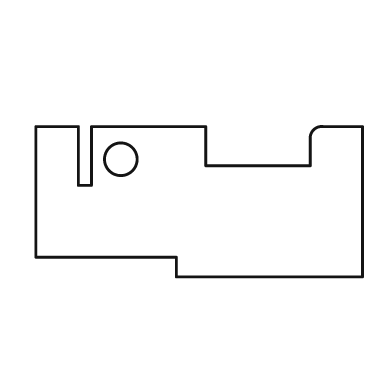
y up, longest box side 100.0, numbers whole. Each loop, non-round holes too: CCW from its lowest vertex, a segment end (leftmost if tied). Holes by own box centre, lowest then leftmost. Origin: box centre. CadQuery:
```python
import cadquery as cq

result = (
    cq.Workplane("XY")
    .moveTo(-7.0, -23.0)
    .lineTo(50.0, -23.0)
    .lineTo(50.0, 23.0)
    .lineTo(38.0, 23.0)
    .threePointArc((35.0, 22.0), (34.0, 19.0))
    .lineTo(34.0, 11.0)
    .lineTo(2.0, 11.0)
    .lineTo(2.0, 23.0)
    .lineTo(-33.0, 23.0)
    .lineTo(-33.0, 5.0)
    .lineTo(-37.0, 5.0)
    .lineTo(-37.0, 23.0)
    .lineTo(-50.0, 23.0)
    .lineTo(-50.0, -17.0)
    .lineTo(-7.0, -17.0)
    .close()
    .moveTo(-24.0, 13.0)
    .circle(5.0)
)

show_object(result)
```